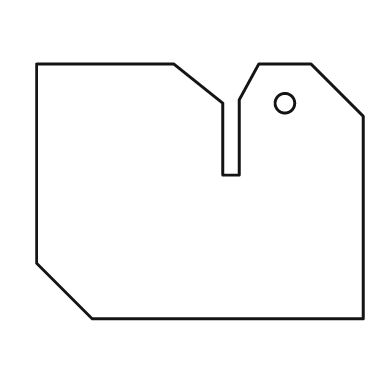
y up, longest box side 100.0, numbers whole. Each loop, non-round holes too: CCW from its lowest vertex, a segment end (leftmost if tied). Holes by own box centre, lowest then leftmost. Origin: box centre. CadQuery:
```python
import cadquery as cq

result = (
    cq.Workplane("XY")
    .moveTo(-33.0, -39.0)
    .lineTo(50.0, -39.0)
    .lineTo(50.0, 23.0)
    .lineTo(34.0, 39.0)
    .lineTo(18.0, 39.0)
    .lineTo(12.0, 28.0)
    .lineTo(12.0, 5.0)
    .lineTo(7.0, 5.0)
    .lineTo(7.0, 27.0)
    .lineTo(-8.0, 39.0)
    .lineTo(-50.0, 39.0)
    .lineTo(-50.0, -22.0)
    .close()
    .moveTo(26.0, 27.0)
    .circle(3.0)
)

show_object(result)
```